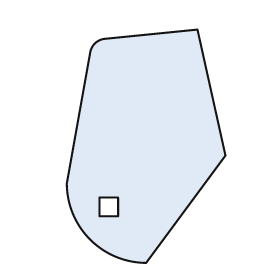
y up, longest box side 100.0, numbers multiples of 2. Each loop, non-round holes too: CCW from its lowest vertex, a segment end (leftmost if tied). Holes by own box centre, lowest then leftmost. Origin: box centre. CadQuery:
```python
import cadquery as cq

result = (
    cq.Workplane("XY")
    .moveTo(0.0, -50.0)
    .lineTo(34.0, -4.0)
    .lineTo(22.0, 50.0)
    .lineTo(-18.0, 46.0)
    .threePointArc((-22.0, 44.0), (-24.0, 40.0))
    .lineTo(-34.0, -16.0)
    .threePointArc((-24.0, -40.0), (0.0, -50.0))
    .close()
    .moveTo(-20.0, -30.0)
    .lineTo(-12.0, -30.0)
    .lineTo(-12.0, -22.0)
    .lineTo(-20.0, -22.0)
    .close()
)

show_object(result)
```